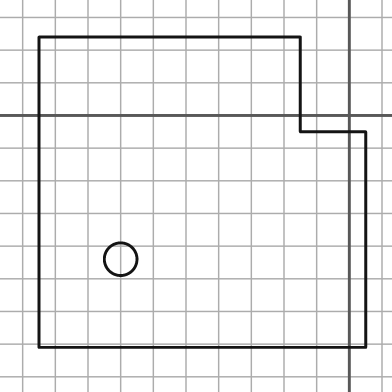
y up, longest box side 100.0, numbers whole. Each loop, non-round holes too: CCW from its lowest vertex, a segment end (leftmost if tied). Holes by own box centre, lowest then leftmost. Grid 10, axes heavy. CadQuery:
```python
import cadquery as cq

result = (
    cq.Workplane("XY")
    .moveTo(-95.0, -71.0)
    .lineTo(5.0, -71.0)
    .lineTo(5.0, -5.0)
    .lineTo(-15.0, -5.0)
    .lineTo(-15.0, 24.0)
    .lineTo(-95.0, 24.0)
    .close()
    .moveTo(-70.0, -44.0)
    .circle(5.0)
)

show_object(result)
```